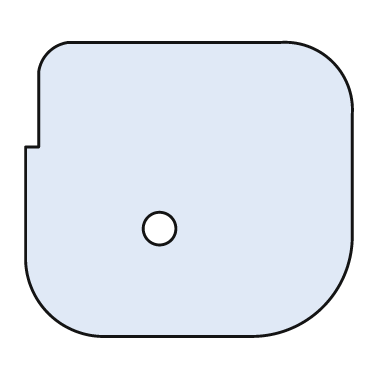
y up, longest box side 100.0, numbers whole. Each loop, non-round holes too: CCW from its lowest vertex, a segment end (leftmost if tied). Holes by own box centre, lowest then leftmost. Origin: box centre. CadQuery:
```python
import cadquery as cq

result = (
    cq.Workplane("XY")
    .moveTo(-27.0, -45.0)
    .lineTo(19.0, -45.0)
    .threePointArc((41.0, -36.0), (50.0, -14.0))
    .lineTo(50.0, 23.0)
    .threePointArc((44.0, 39.0), (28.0, 45.0))
    .lineTo(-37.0, 45.0)
    .threePointArc((-43.0, 42.0), (-46.0, 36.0))
    .lineTo(-46.0, 13.0)
    .lineTo(-50.0, 13.0)
    .lineTo(-50.0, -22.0)
    .threePointArc((-43.0, -38.0), (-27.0, -45.0))
    .close()
    .moveTo(-9.0, -12.0)
    .circle(5.0)
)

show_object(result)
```